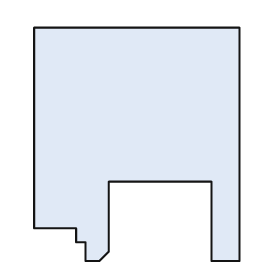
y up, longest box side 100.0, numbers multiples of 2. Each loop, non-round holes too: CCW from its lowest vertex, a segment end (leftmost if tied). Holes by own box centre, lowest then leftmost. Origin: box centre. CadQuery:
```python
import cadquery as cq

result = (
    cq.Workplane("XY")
    .moveTo(-22.0, -50.0)
    .lineTo(-16.0, -50.0)
    .lineTo(-12.0, -46.0)
    .lineTo(-12.0, -16.0)
    .lineTo(32.0, -16.0)
    .lineTo(32.0, -50.0)
    .lineTo(44.0, -50.0)
    .lineTo(44.0, 50.0)
    .lineTo(-44.0, 50.0)
    .lineTo(-44.0, -36.0)
    .lineTo(-26.0, -36.0)
    .lineTo(-26.0, -42.0)
    .lineTo(-22.0, -42.0)
    .close()
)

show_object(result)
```